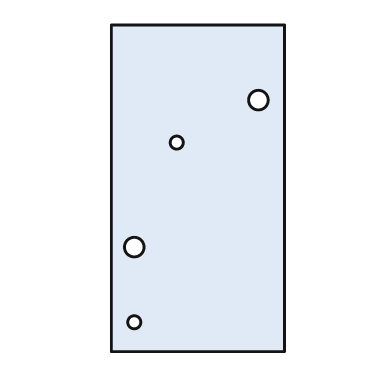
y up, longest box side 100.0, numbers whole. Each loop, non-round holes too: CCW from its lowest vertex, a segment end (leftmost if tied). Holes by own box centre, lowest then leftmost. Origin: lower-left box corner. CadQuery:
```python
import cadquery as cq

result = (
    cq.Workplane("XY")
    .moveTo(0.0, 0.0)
    .lineTo(53.0, 0.0)
    .lineTo(53.0, 100.0)
    .lineTo(0.0, 100.0)
    .close()
    .moveTo(7.0, 9.0)
    .circle(2.0)
    .moveTo(7.0, 32.0)
    .circle(3.0)
    .moveTo(20.0, 64.0)
    .circle(2.0)
    .moveTo(45.0, 77.0)
    .circle(3.0)
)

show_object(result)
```